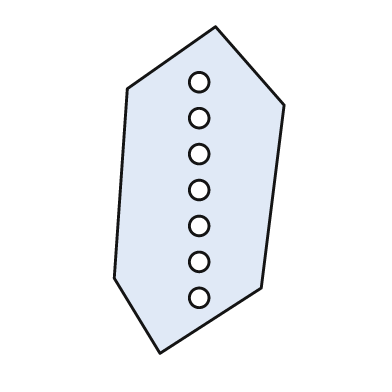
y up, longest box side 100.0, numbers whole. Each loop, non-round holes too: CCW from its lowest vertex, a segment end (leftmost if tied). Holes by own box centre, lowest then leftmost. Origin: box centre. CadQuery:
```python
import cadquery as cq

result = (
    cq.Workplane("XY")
    .moveTo(-12.0, -50.0)
    .lineTo(19.0, -30.0)
    .lineTo(26.0, 26.0)
    .lineTo(5.0, 50.0)
    .lineTo(-22.0, 31.0)
    .lineTo(-26.0, -27.0)
    .close()
    .moveTo(0.0, -33.0)
    .circle(3.0)
    .moveTo(0.0, -22.0)
    .circle(3.0)
    .moveTo(0.0, -11.0)
    .circle(3.0)
    .moveTo(0.0, 0.0)
    .circle(3.0)
    .moveTo(0.0, 11.0)
    .circle(3.0)
    .moveTo(0.0, 22.0)
    .circle(3.0)
    .moveTo(0.0, 33.0)
    .circle(3.0)
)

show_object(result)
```